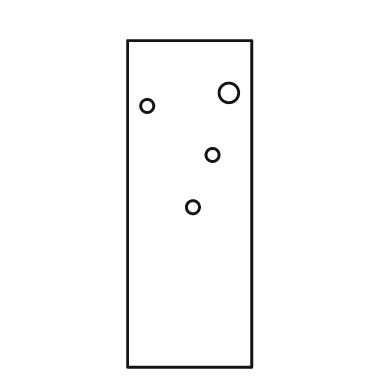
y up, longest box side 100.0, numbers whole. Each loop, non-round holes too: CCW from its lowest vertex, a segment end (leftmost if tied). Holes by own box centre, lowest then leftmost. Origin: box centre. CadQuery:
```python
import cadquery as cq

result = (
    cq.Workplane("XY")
    .moveTo(-19.0, -50.0)
    .lineTo(19.0, -50.0)
    .lineTo(19.0, 50.0)
    .lineTo(-19.0, 50.0)
    .close()
    .moveTo(1.0, -1.0)
    .circle(2.0)
    .moveTo(7.0, 15.0)
    .circle(2.0)
    .moveTo(-13.0, 30.0)
    .circle(2.0)
    .moveTo(12.0, 34.0)
    .circle(3.0)
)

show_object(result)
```